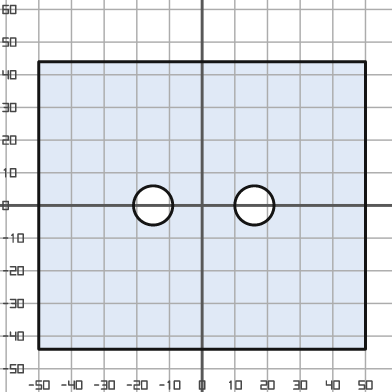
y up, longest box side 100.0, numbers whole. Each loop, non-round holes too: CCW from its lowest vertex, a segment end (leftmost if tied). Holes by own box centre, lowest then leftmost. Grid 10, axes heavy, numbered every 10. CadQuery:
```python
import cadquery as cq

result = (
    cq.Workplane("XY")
    .moveTo(-50.0, -44.0)
    .lineTo(50.0, -44.0)
    .lineTo(50.0, 44.0)
    .lineTo(-50.0, 44.0)
    .close()
    .moveTo(-15.0, 0.0)
    .circle(6.0)
    .moveTo(16.0, 0.0)
    .circle(6.0)
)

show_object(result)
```